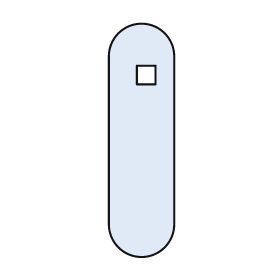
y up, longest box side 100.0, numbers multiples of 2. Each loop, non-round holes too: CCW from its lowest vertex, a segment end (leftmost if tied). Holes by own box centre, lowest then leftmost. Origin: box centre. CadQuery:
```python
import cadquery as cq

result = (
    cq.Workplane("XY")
    .moveTo(-14.0, -36.0)
    .threePointArc((0.0, -50.0), (14.0, -36.0))
    .lineTo(14.0, 36.0)
    .threePointArc((0.0, 50.0), (-14.0, 36.0))
    .close()
    .moveTo(-2.0, 24.0)
    .lineTo(6.0, 24.0)
    .lineTo(6.0, 32.0)
    .lineTo(-2.0, 32.0)
    .close()
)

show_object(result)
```